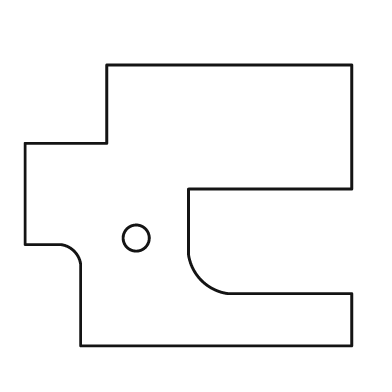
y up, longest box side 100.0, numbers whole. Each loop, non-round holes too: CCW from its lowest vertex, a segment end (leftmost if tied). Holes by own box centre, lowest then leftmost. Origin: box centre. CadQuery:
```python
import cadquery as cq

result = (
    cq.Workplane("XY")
    .moveTo(-33.0, -43.0)
    .lineTo(50.0, -43.0)
    .lineTo(50.0, -27.0)
    .lineTo(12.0, -27.0)
    .threePointArc((4.0, -23.0), (0.0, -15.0))
    .lineTo(0.0, 5.0)
    .lineTo(50.0, 5.0)
    .lineTo(50.0, 43.0)
    .lineTo(-25.0, 43.0)
    .lineTo(-25.0, 19.0)
    .lineTo(-50.0, 19.0)
    .lineTo(-50.0, -12.0)
    .lineTo(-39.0, -12.0)
    .threePointArc((-35.0, -14.0), (-33.0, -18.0))
    .close()
    .moveTo(-16.0, -10.0)
    .circle(4.0)
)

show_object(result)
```